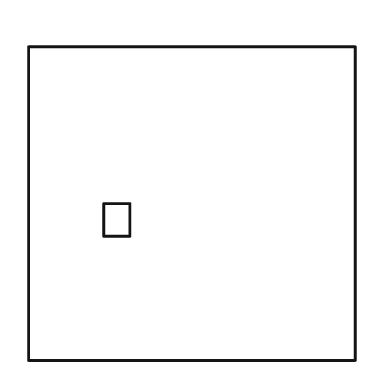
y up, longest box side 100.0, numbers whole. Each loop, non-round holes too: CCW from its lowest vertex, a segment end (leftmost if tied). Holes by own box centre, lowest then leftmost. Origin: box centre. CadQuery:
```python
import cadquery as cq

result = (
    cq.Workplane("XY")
    .moveTo(-50.0, -48.0)
    .lineTo(50.0, -48.0)
    .lineTo(50.0, 48.0)
    .lineTo(-50.0, 48.0)
    .close()
    .moveTo(-27.0, -10.0)
    .lineTo(-19.0, -10.0)
    .lineTo(-19.0, 0.0)
    .lineTo(-27.0, 0.0)
    .close()
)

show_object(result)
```